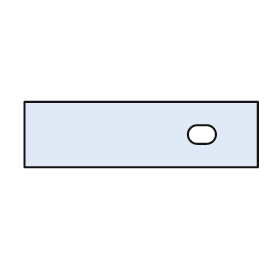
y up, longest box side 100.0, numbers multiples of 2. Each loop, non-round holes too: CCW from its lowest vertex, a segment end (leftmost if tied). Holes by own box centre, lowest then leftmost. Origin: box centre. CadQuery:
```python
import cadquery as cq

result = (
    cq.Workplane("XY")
    .moveTo(-50.0, -14.0)
    .lineTo(50.0, -14.0)
    .lineTo(50.0, 14.0)
    .lineTo(-50.0, 14.0)
    .close()
    .moveTo(24.0, -4.0)
    .lineTo(28.0, -4.0)
    .threePointArc((32.0, 0.0), (28.0, 4.0))
    .lineTo(24.0, 4.0)
    .threePointArc((20.0, 0.0), (24.0, -4.0))
    .close()
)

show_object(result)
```